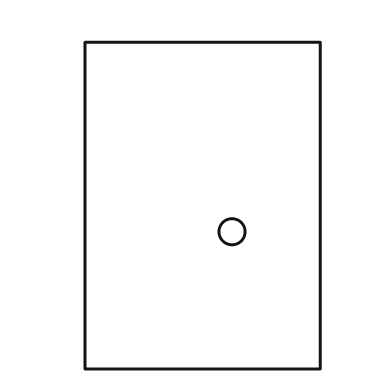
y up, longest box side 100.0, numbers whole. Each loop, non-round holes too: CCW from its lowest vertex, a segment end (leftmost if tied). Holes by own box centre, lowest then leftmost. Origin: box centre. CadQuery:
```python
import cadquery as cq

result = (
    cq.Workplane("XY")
    .moveTo(-36.0, -50.0)
    .lineTo(36.0, -50.0)
    .lineTo(36.0, 50.0)
    .lineTo(-36.0, 50.0)
    .close()
    .moveTo(9.0, -8.0)
    .circle(4.0)
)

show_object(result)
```